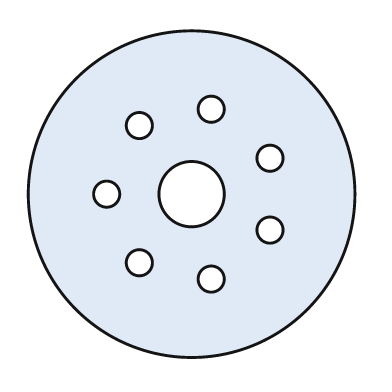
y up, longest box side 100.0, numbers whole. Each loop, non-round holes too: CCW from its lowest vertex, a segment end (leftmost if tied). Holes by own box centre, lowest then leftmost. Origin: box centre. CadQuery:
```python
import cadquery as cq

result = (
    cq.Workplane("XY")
    .moveTo(0.0, 0.0)
    .circle(50.0)
    .moveTo(6.0, -26.0)
    .circle(4.0)
    .moveTo(-16.0, -21.0)
    .circle(4.0)
    .moveTo(24.0, -11.0)
    .circle(4.0)
    .moveTo(-26.0, 0.0)
    .circle(4.0)
    .moveTo(0.0, 0.0)
    .circle(10.0)
    .moveTo(24.0, 11.0)
    .circle(4.0)
    .moveTo(-16.0, 21.0)
    .circle(4.0)
    .moveTo(6.0, 26.0)
    .circle(4.0)
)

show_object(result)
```